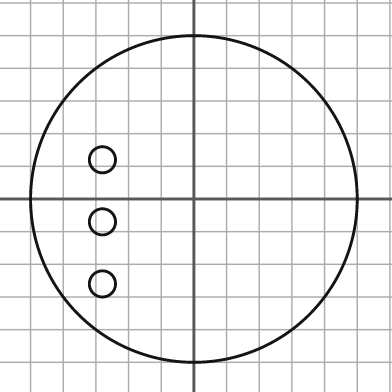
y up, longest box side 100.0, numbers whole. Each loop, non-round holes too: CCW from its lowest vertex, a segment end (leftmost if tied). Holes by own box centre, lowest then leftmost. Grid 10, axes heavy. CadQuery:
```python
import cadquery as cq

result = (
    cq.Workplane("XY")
    .moveTo(0.0, 0.0)
    .circle(50.0)
    .moveTo(-28.0, -26.0)
    .circle(4.0)
    .moveTo(-28.0, -7.0)
    .circle(4.0)
    .moveTo(-28.0, 12.0)
    .circle(4.0)
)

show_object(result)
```